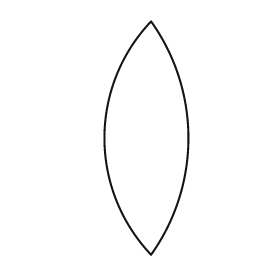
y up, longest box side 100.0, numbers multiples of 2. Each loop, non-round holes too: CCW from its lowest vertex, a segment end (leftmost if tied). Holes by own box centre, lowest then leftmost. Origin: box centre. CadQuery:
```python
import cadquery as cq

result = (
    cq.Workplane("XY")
    .moveTo(2.0, -50.0)
    .threePointArc((18.0, 0.0), (2.0, 50.0))
    .threePointArc((-18.0, 0.0), (2.0, -50.0))
    .close()
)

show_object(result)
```